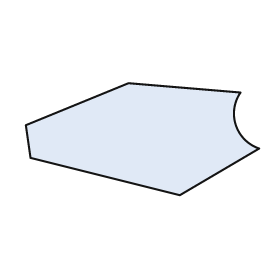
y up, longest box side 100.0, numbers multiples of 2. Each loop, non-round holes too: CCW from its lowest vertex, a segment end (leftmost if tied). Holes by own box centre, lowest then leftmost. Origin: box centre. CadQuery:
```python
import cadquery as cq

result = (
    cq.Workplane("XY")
    .moveTo(16.0, -24.0)
    .lineTo(50.0, -4.0)
    .threePointArc((40.0, 6.0), (42.0, 20.0))
    .lineTo(-6.0, 24.0)
    .lineTo(-50.0, 6.0)
    .lineTo(-48.0, -8.0)
    .close()
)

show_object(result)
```